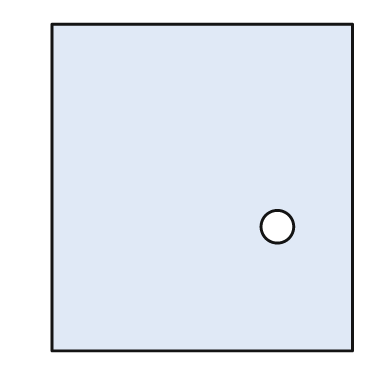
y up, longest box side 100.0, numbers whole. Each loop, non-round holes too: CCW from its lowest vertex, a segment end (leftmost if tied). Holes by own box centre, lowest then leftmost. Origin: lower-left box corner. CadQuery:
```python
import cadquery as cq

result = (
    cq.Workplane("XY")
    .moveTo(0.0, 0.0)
    .lineTo(92.0, 0.0)
    .lineTo(92.0, 100.0)
    .lineTo(0.0, 100.0)
    .close()
    .moveTo(69.0, 38.0)
    .circle(5.0)
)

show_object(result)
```